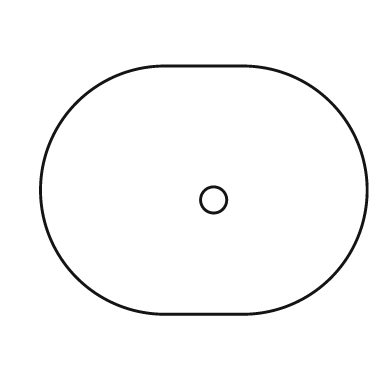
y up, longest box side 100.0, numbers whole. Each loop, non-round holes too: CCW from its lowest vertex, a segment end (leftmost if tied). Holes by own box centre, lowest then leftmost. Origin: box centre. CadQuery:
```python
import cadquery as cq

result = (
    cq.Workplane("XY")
    .moveTo(-12.0, -38.0)
    .lineTo(12.0, -38.0)
    .threePointArc((50.0, 0.0), (12.0, 38.0))
    .lineTo(-12.0, 38.0)
    .threePointArc((-50.0, 0.0), (-12.0, -38.0))
    .close()
    .moveTo(3.0, -3.0)
    .circle(4.0)
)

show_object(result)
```